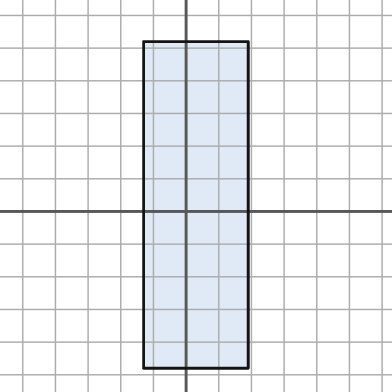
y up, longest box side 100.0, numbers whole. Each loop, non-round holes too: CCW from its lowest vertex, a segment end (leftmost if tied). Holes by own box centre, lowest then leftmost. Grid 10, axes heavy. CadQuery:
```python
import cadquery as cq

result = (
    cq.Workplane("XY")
    .moveTo(-13.0, -48.0)
    .lineTo(19.0, -48.0)
    .lineTo(19.0, 52.0)
    .lineTo(-13.0, 52.0)
    .close()
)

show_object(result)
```